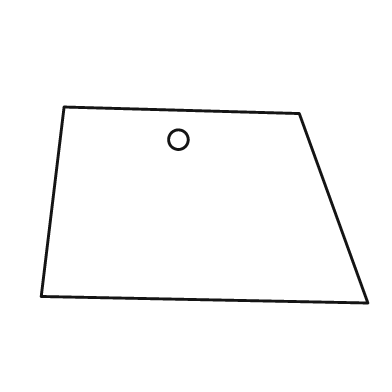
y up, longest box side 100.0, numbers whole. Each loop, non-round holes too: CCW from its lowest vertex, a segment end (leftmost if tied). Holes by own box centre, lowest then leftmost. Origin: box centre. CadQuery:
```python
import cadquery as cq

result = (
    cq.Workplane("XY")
    .moveTo(50.0, -30.0)
    .lineTo(29.0, 28.0)
    .lineTo(-43.0, 30.0)
    .lineTo(-50.0, -28.0)
    .close()
    .moveTo(-8.0, 20.0)
    .circle(3.0)
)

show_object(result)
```